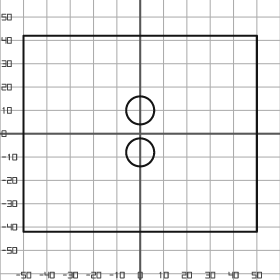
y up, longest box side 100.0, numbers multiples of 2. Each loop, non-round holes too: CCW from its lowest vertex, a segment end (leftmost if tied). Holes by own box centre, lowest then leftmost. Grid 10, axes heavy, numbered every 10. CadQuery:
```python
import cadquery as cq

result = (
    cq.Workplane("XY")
    .moveTo(-50.0, -42.0)
    .lineTo(50.0, -42.0)
    .lineTo(50.0, 42.0)
    .lineTo(-50.0, 42.0)
    .close()
    .moveTo(0.0, -8.0)
    .circle(6.0)
    .moveTo(0.0, 10.0)
    .circle(6.0)
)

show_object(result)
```